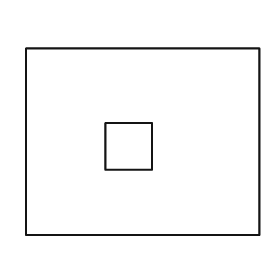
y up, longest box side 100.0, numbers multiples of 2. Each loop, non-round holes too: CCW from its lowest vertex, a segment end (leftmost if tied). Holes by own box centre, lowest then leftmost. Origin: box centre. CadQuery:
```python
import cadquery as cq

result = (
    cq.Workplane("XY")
    .moveTo(-50.0, -40.0)
    .lineTo(50.0, -40.0)
    .lineTo(50.0, 40.0)
    .lineTo(-50.0, 40.0)
    .close()
    .moveTo(-16.0, -12.0)
    .lineTo(4.0, -12.0)
    .lineTo(4.0, 8.0)
    .lineTo(-16.0, 8.0)
    .close()
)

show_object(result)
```